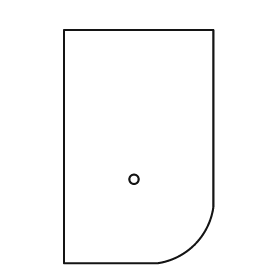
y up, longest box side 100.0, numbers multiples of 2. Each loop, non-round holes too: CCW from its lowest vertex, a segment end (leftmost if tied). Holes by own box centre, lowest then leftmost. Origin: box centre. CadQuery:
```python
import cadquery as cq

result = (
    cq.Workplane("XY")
    .moveTo(-32.0, -50.0)
    .lineTo(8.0, -50.0)
    .threePointArc((24.0, -42.0), (32.0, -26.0))
    .lineTo(32.0, 50.0)
    .lineTo(-32.0, 50.0)
    .close()
    .moveTo(-2.0, -14.0)
    .circle(2.0)
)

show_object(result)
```